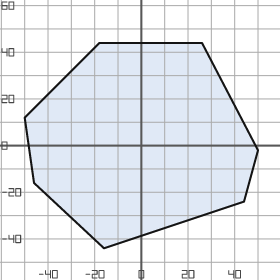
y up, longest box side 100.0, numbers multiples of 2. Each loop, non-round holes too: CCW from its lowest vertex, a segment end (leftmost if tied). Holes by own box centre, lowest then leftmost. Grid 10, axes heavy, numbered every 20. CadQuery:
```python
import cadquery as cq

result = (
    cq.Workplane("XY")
    .moveTo(-16.0, -44.0)
    .lineTo(44.0, -24.0)
    .lineTo(50.0, -2.0)
    .lineTo(26.0, 44.0)
    .lineTo(-18.0, 44.0)
    .lineTo(-50.0, 12.0)
    .lineTo(-46.0, -16.0)
    .close()
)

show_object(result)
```